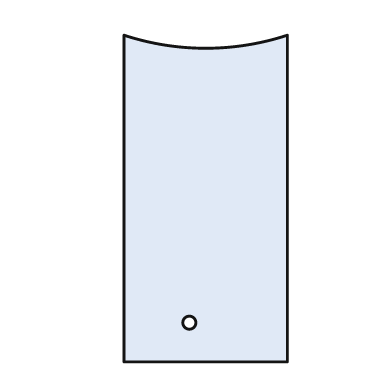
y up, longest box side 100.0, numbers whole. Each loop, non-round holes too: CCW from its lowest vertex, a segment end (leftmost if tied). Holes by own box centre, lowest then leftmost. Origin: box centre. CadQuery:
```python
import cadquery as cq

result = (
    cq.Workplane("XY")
    .moveTo(-25.0, -50.0)
    .lineTo(25.0, -50.0)
    .lineTo(25.0, 50.0)
    .threePointArc((0.0, 46.0), (-25.0, 50.0))
    .close()
    .moveTo(-5.0, -38.0)
    .circle(2.0)
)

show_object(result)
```